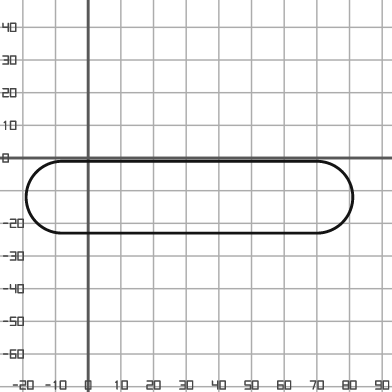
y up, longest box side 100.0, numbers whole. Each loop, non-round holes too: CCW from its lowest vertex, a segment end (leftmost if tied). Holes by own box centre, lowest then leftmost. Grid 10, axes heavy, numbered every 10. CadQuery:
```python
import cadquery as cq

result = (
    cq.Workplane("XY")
    .moveTo(-8.0, -23.0)
    .lineTo(70.0, -23.0)
    .threePointArc((81.0, -12.0), (70.0, -1.0))
    .lineTo(-8.0, -1.0)
    .threePointArc((-19.0, -12.0), (-8.0, -23.0))
    .close()
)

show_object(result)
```